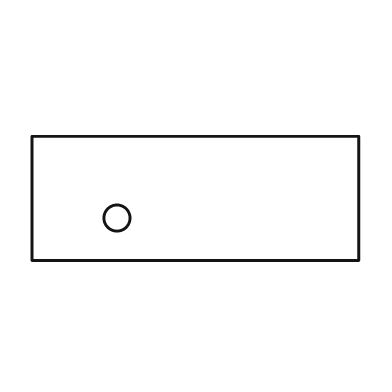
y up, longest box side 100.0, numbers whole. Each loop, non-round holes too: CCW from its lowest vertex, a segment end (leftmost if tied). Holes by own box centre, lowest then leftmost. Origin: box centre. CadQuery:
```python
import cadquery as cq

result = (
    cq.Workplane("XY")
    .moveTo(-50.0, -19.0)
    .lineTo(50.0, -19.0)
    .lineTo(50.0, 19.0)
    .lineTo(-50.0, 19.0)
    .close()
    .moveTo(-24.0, -6.0)
    .circle(4.0)
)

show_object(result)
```